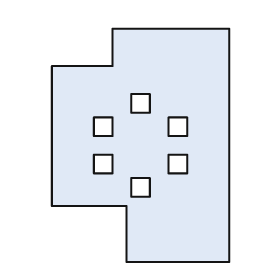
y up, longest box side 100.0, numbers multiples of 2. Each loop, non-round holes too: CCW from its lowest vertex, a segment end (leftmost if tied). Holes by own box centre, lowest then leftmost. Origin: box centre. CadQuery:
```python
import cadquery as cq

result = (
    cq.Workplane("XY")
    .moveTo(-6.0, -50.0)
    .lineTo(38.0, -50.0)
    .lineTo(38.0, 50.0)
    .lineTo(-12.0, 50.0)
    .lineTo(-12.0, 34.0)
    .lineTo(-38.0, 34.0)
    .lineTo(-38.0, -26.0)
    .lineTo(-6.0, -26.0)
    .close()
    .moveTo(-4.0, -22.0)
    .lineTo(4.0, -22.0)
    .lineTo(4.0, -14.0)
    .lineTo(-4.0, -14.0)
    .close()
    .moveTo(-20.0, -12.0)
    .lineTo(-12.0, -12.0)
    .lineTo(-12.0, -4.0)
    .lineTo(-20.0, -4.0)
    .close()
    .moveTo(12.0, -12.0)
    .lineTo(20.0, -12.0)
    .lineTo(20.0, -4.0)
    .lineTo(12.0, -4.0)
    .close()
    .moveTo(-20.0, 4.0)
    .lineTo(-12.0, 4.0)
    .lineTo(-12.0, 12.0)
    .lineTo(-20.0, 12.0)
    .close()
    .moveTo(12.0, 4.0)
    .lineTo(20.0, 4.0)
    .lineTo(20.0, 12.0)
    .lineTo(12.0, 12.0)
    .close()
    .moveTo(-4.0, 14.0)
    .lineTo(4.0, 14.0)
    .lineTo(4.0, 22.0)
    .lineTo(-4.0, 22.0)
    .close()
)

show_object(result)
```